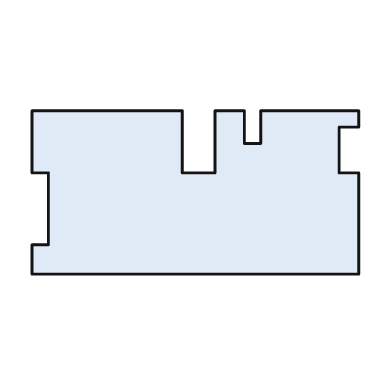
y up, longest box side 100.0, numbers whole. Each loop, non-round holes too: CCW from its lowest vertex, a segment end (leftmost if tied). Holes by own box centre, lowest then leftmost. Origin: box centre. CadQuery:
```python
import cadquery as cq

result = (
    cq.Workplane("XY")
    .moveTo(-50.0, -25.0)
    .lineTo(50.0, -25.0)
    .lineTo(50.0, 6.0)
    .lineTo(44.0, 6.0)
    .lineTo(44.0, 20.0)
    .lineTo(50.0, 20.0)
    .lineTo(50.0, 25.0)
    .lineTo(20.0, 25.0)
    .lineTo(20.0, 15.0)
    .lineTo(15.0, 15.0)
    .lineTo(15.0, 25.0)
    .lineTo(6.0, 25.0)
    .lineTo(6.0, 6.0)
    .lineTo(-4.0, 6.0)
    .lineTo(-4.0, 25.0)
    .lineTo(-50.0, 25.0)
    .lineTo(-50.0, 6.0)
    .lineTo(-45.0, 6.0)
    .lineTo(-45.0, -16.0)
    .lineTo(-50.0, -16.0)
    .close()
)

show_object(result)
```